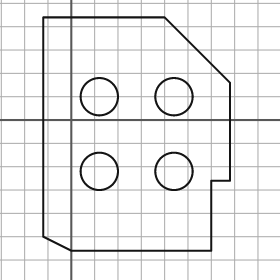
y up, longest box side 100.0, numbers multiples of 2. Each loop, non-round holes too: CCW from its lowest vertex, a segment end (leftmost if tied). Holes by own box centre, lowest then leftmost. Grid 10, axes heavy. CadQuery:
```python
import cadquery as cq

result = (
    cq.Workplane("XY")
    .moveTo(0.0, -56.0)
    .lineTo(60.0, -56.0)
    .lineTo(60.0, -26.0)
    .lineTo(68.0, -26.0)
    .lineTo(68.0, 16.0)
    .lineTo(40.0, 44.0)
    .lineTo(-12.0, 44.0)
    .lineTo(-12.0, -50.0)
    .close()
    .moveTo(12.0, -22.0)
    .circle(8.0)
    .moveTo(44.0, -22.0)
    .circle(8.0)
    .moveTo(12.0, 10.0)
    .circle(8.0)
    .moveTo(44.0, 10.0)
    .circle(8.0)
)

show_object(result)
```